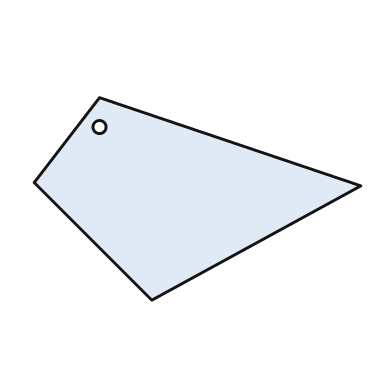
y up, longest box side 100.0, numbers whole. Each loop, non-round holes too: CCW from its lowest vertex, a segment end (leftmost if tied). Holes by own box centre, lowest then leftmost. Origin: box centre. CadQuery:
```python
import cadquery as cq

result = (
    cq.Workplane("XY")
    .moveTo(-14.0, -31.0)
    .lineTo(50.0, 4.0)
    .lineTo(-30.0, 31.0)
    .lineTo(-50.0, 5.0)
    .close()
    .moveTo(-30.0, 22.0)
    .circle(2.0)
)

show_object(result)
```